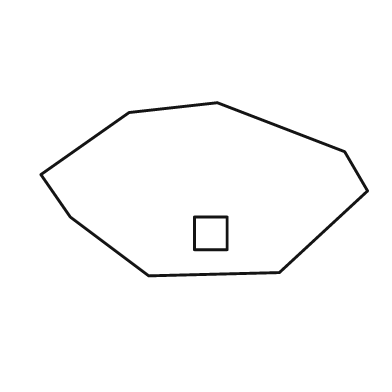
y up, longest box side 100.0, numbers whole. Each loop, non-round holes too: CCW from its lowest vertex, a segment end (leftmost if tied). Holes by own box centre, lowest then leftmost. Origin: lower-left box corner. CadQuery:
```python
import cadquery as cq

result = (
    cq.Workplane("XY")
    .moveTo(33.0, 0.0)
    .lineTo(73.0, 1.0)
    .lineTo(100.0, 26.0)
    .lineTo(93.0, 38.0)
    .lineTo(54.0, 53.0)
    .lineTo(27.0, 50.0)
    .lineTo(0.0, 31.0)
    .lineTo(9.0, 18.0)
    .close()
    .moveTo(47.0, 8.0)
    .lineTo(57.0, 8.0)
    .lineTo(57.0, 18.0)
    .lineTo(47.0, 18.0)
    .close()
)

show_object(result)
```